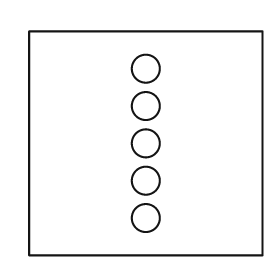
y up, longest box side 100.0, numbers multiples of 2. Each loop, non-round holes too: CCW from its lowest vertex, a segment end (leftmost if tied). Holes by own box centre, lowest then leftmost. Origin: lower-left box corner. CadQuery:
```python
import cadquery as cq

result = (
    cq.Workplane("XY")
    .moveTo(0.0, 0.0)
    .lineTo(100.0, 0.0)
    .lineTo(100.0, 96.0)
    .lineTo(0.0, 96.0)
    .close()
    .moveTo(50.0, 16.0)
    .circle(6.0)
    .moveTo(50.0, 32.0)
    .circle(6.0)
    .moveTo(50.0, 48.0)
    .circle(6.0)
    .moveTo(50.0, 64.0)
    .circle(6.0)
    .moveTo(50.0, 80.0)
    .circle(6.0)
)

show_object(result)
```